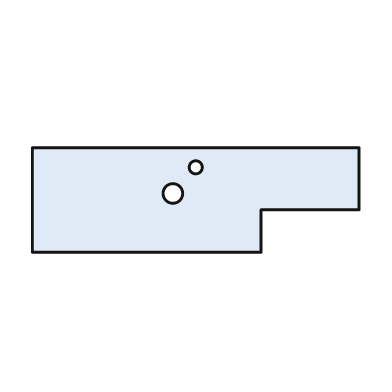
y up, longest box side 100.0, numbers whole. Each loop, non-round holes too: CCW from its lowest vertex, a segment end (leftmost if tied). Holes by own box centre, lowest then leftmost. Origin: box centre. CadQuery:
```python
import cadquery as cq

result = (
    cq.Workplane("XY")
    .moveTo(-50.0, -16.0)
    .lineTo(20.0, -16.0)
    .lineTo(20.0, -3.0)
    .lineTo(50.0, -3.0)
    .lineTo(50.0, 16.0)
    .lineTo(-50.0, 16.0)
    .close()
    .moveTo(-7.0, 2.0)
    .circle(3.0)
    .moveTo(0.0, 10.0)
    .circle(2.0)
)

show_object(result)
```